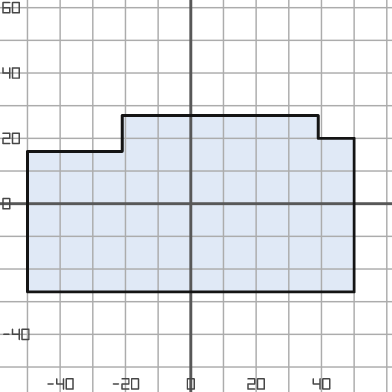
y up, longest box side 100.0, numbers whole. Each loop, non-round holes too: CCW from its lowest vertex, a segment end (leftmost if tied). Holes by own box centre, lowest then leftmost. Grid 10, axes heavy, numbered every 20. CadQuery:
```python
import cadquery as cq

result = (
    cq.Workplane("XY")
    .moveTo(-50.0, -27.0)
    .lineTo(50.0, -27.0)
    .lineTo(50.0, 20.0)
    .lineTo(39.0, 20.0)
    .lineTo(39.0, 27.0)
    .lineTo(-21.0, 27.0)
    .lineTo(-21.0, 16.0)
    .lineTo(-50.0, 16.0)
    .close()
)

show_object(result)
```